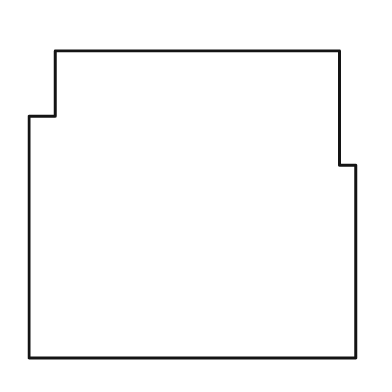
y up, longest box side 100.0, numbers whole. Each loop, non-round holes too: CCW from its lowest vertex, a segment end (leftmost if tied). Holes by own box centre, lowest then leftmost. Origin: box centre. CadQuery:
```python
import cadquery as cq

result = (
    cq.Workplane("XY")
    .moveTo(-50.0, -47.0)
    .lineTo(50.0, -47.0)
    .lineTo(50.0, 12.0)
    .lineTo(45.0, 12.0)
    .lineTo(45.0, 47.0)
    .lineTo(-42.0, 47.0)
    .lineTo(-42.0, 27.0)
    .lineTo(-50.0, 27.0)
    .close()
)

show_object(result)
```